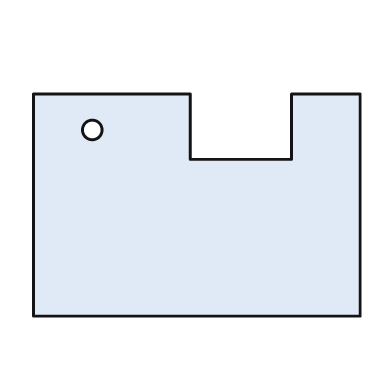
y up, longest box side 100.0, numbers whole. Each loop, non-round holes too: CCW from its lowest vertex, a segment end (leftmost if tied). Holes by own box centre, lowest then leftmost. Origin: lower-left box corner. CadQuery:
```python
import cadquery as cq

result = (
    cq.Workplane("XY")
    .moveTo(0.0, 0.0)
    .lineTo(100.0, 0.0)
    .lineTo(100.0, 68.0)
    .lineTo(79.0, 68.0)
    .lineTo(79.0, 48.0)
    .lineTo(48.0, 48.0)
    .lineTo(48.0, 68.0)
    .lineTo(0.0, 68.0)
    .close()
    .moveTo(18.0, 57.0)
    .circle(3.0)
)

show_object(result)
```